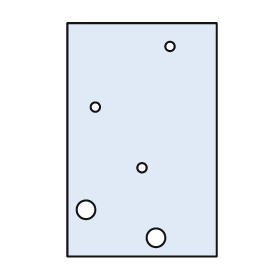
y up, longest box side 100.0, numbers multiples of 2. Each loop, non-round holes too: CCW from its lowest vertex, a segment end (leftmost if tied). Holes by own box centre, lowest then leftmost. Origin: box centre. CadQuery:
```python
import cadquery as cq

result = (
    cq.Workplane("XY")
    .moveTo(-32.0, -50.0)
    .lineTo(32.0, -50.0)
    .lineTo(32.0, 50.0)
    .lineTo(-32.0, 50.0)
    .close()
    .moveTo(6.0, -42.0)
    .circle(4.0)
    .moveTo(-24.0, -30.0)
    .circle(4.0)
    .moveTo(0.0, -12.0)
    .circle(2.0)
    .moveTo(-20.0, 14.0)
    .circle(2.0)
    .moveTo(12.0, 40.0)
    .circle(2.0)
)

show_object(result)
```